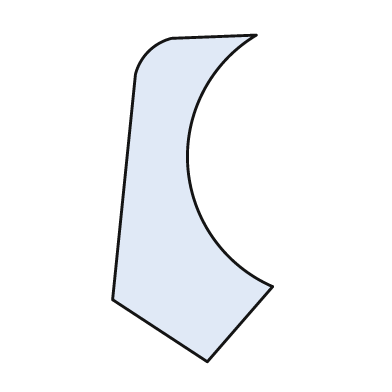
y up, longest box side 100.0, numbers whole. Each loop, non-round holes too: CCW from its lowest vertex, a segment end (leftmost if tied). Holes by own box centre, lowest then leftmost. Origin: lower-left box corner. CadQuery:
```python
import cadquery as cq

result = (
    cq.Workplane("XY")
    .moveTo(29.0, 0.0)
    .lineTo(49.0, 23.0)
    .threePointArc((23.0, 60.0), (44.0, 100.0))
    .lineTo(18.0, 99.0)
    .threePointArc((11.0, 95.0), (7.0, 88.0))
    .lineTo(0.0, 19.0)
    .close()
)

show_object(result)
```